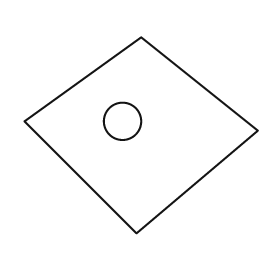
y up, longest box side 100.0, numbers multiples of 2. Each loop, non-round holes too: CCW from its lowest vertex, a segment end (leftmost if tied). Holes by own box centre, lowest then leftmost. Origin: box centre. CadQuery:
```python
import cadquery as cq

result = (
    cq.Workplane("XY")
    .moveTo(-2.0, -42.0)
    .lineTo(50.0, 2.0)
    .lineTo(0.0, 42.0)
    .lineTo(-50.0, 6.0)
    .close()
    .moveTo(-8.0, 6.0)
    .circle(8.0)
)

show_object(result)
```